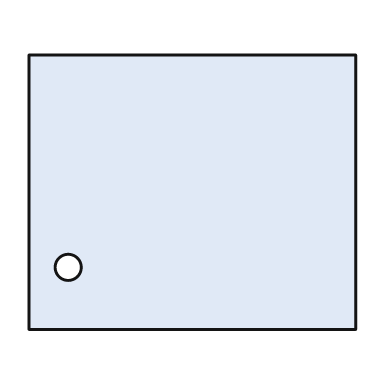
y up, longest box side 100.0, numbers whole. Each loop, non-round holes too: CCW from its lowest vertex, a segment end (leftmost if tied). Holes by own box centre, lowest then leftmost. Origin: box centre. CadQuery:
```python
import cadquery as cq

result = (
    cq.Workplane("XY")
    .moveTo(-50.0, -42.0)
    .lineTo(50.0, -42.0)
    .lineTo(50.0, 42.0)
    .lineTo(-50.0, 42.0)
    .close()
    .moveTo(-38.0, -23.0)
    .circle(4.0)
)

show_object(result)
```